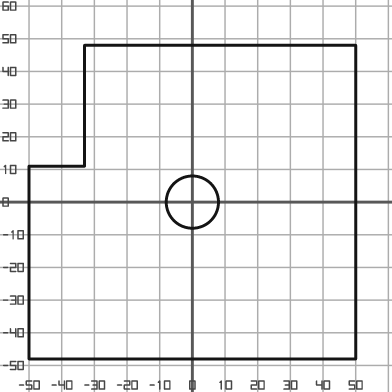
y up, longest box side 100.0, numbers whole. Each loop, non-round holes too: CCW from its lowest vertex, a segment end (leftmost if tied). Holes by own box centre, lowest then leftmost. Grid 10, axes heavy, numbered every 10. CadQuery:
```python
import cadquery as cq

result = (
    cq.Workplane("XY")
    .moveTo(-50.0, -48.0)
    .lineTo(50.0, -48.0)
    .lineTo(50.0, 48.0)
    .lineTo(-33.0, 48.0)
    .lineTo(-33.0, 11.0)
    .lineTo(-50.0, 11.0)
    .close()
    .moveTo(0.0, 0.0)
    .circle(8.0)
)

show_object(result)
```